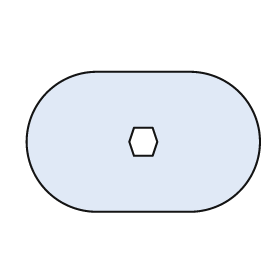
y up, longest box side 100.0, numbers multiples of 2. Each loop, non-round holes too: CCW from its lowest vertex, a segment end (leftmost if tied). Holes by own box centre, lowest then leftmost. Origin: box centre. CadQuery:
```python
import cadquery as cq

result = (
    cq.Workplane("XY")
    .moveTo(-20.0, -30.0)
    .lineTo(20.0, -30.0)
    .threePointArc((50.0, 0.0), (20.0, 30.0))
    .lineTo(-20.0, 30.0)
    .threePointArc((-50.0, 0.0), (-20.0, -30.0))
    .close()
    .moveTo(-4.0, -6.0)
    .lineTo(4.0, -6.0)
    .lineTo(6.0, 0.0)
    .lineTo(4.0, 6.0)
    .lineTo(-4.0, 6.0)
    .lineTo(-6.0, 0.0)
    .close()
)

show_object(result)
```